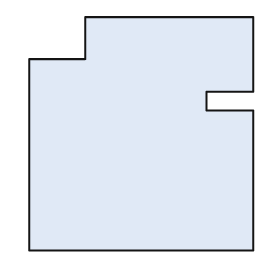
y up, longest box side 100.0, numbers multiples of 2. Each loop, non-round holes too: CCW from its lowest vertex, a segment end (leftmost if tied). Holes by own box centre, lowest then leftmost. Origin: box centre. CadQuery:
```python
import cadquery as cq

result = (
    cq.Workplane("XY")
    .moveTo(-48.0, -50.0)
    .lineTo(48.0, -50.0)
    .lineTo(48.0, 10.0)
    .lineTo(28.0, 10.0)
    .lineTo(28.0, 18.0)
    .lineTo(48.0, 18.0)
    .lineTo(48.0, 50.0)
    .lineTo(-24.0, 50.0)
    .lineTo(-24.0, 32.0)
    .lineTo(-48.0, 32.0)
    .close()
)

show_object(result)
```